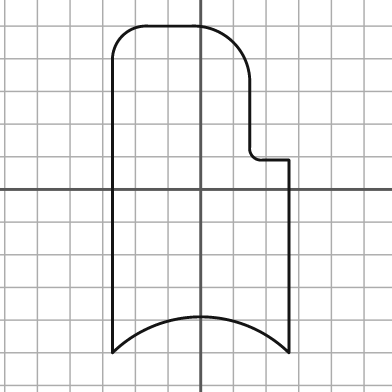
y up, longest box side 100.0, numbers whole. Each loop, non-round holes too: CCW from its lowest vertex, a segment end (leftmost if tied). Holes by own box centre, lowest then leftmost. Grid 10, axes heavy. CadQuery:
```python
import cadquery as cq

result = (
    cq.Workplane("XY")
    .moveTo(-27.0, -50.0)
    .threePointArc((0.0, -39.0), (27.0, -50.0))
    .lineTo(27.0, 9.0)
    .lineTo(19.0, 9.0)
    .threePointArc((16.0, 10.0), (15.0, 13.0))
    .lineTo(15.0, 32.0)
    .threePointArc((10.0, 45.0), (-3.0, 50.0))
    .lineTo(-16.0, 50.0)
    .threePointArc((-24.0, 47.0), (-27.0, 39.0))
    .close()
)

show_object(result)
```